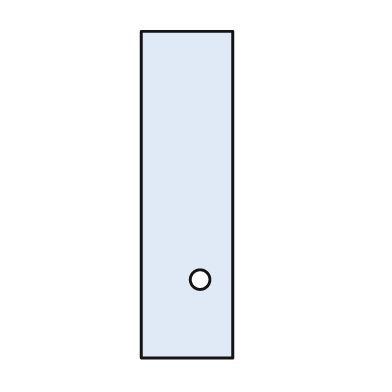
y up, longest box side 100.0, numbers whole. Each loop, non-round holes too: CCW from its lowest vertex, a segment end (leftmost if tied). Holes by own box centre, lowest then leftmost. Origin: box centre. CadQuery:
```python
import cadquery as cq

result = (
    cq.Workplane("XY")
    .moveTo(-14.0, -50.0)
    .lineTo(14.0, -50.0)
    .lineTo(14.0, 50.0)
    .lineTo(-14.0, 50.0)
    .close()
    .moveTo(4.0, -26.0)
    .circle(3.0)
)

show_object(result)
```